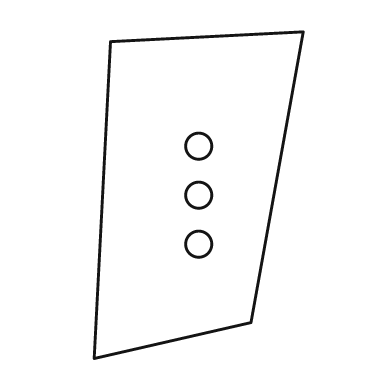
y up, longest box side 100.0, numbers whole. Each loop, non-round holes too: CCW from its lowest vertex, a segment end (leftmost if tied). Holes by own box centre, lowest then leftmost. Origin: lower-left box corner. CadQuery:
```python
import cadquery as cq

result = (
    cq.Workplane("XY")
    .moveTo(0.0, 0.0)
    .lineTo(48.0, 11.0)
    .lineTo(64.0, 100.0)
    .lineTo(5.0, 97.0)
    .close()
    .moveTo(32.0, 35.0)
    .circle(4.0)
    .moveTo(32.0, 50.0)
    .circle(4.0)
    .moveTo(32.0, 65.0)
    .circle(4.0)
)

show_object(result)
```